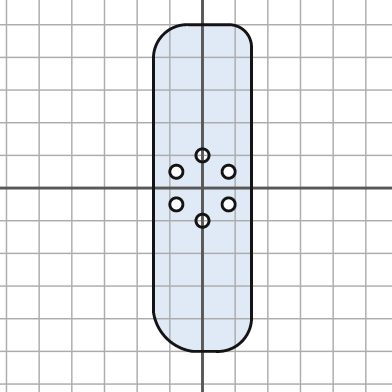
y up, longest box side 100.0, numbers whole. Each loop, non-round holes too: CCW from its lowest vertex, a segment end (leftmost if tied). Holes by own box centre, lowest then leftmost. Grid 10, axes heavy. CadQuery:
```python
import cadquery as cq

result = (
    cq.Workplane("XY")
    .moveTo(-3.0, -50.0)
    .lineTo(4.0, -50.0)
    .threePointArc((12.0, -47.0), (15.0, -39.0))
    .lineTo(15.0, 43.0)
    .threePointArc((13.0, 48.0), (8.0, 50.0))
    .lineTo(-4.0, 50.0)
    .threePointArc((-12.0, 47.0), (-15.0, 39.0))
    .lineTo(-15.0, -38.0)
    .threePointArc((-11.0, -46.0), (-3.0, -50.0))
    .close()
    .moveTo(0.0, -10.0)
    .circle(2.0)
    .moveTo(-8.0, -5.0)
    .circle(2.0)
    .moveTo(8.0, -5.0)
    .circle(2.0)
    .moveTo(-8.0, 5.0)
    .circle(2.0)
    .moveTo(8.0, 5.0)
    .circle(2.0)
    .moveTo(0.0, 10.0)
    .circle(2.0)
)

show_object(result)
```